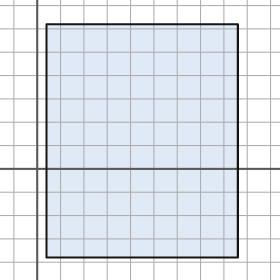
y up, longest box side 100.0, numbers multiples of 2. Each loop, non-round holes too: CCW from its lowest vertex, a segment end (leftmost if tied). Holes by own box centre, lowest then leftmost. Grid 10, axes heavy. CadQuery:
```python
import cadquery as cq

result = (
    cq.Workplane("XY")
    .moveTo(4.0, -38.0)
    .lineTo(86.0, -38.0)
    .lineTo(86.0, 62.0)
    .lineTo(4.0, 62.0)
    .close()
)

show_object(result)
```